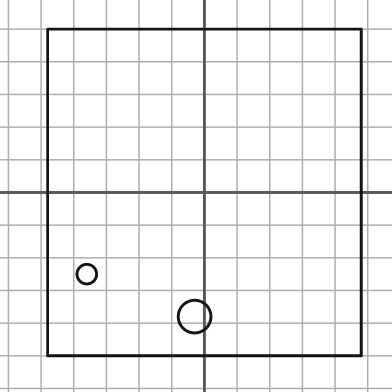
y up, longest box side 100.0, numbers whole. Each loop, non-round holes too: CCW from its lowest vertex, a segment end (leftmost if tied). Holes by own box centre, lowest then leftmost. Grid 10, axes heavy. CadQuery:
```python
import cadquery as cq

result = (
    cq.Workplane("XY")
    .moveTo(-48.0, -50.0)
    .lineTo(48.0, -50.0)
    .lineTo(48.0, 50.0)
    .lineTo(-48.0, 50.0)
    .close()
    .moveTo(-3.0, -38.0)
    .circle(5.0)
    .moveTo(-36.0, -25.0)
    .circle(3.0)
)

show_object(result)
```